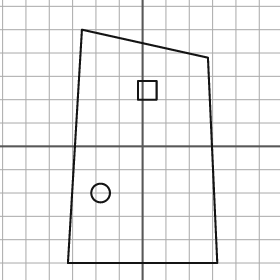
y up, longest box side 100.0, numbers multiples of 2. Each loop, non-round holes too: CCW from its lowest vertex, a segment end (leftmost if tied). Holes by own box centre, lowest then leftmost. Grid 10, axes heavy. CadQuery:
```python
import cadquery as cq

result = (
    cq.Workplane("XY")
    .moveTo(-32.0, -50.0)
    .lineTo(32.0, -50.0)
    .lineTo(28.0, 38.0)
    .lineTo(-26.0, 50.0)
    .close()
    .moveTo(-18.0, -20.0)
    .circle(4.0)
    .moveTo(-2.0, 20.0)
    .lineTo(6.0, 20.0)
    .lineTo(6.0, 28.0)
    .lineTo(-2.0, 28.0)
    .close()
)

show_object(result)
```